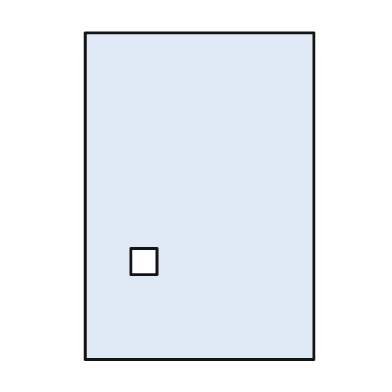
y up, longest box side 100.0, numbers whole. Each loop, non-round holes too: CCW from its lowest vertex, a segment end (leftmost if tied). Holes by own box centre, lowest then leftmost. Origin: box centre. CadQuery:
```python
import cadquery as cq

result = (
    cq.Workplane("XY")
    .moveTo(-35.0, -50.0)
    .lineTo(35.0, -50.0)
    .lineTo(35.0, 50.0)
    .lineTo(-35.0, 50.0)
    .close()
    .moveTo(-21.0, -24.0)
    .lineTo(-13.0, -24.0)
    .lineTo(-13.0, -16.0)
    .lineTo(-21.0, -16.0)
    .close()
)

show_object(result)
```